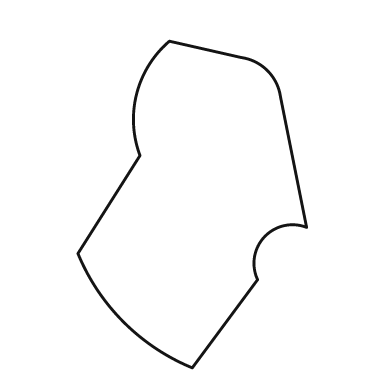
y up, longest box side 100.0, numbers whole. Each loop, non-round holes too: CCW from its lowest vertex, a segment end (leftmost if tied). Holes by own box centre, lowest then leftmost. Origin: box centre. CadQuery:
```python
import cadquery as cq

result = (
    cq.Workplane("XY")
    .moveTo(0.0, -50.0)
    .lineTo(20.0, -23.0)
    .threePointArc((22.0, -10.0), (35.0, -7.0))
    .lineTo(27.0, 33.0)
    .threePointArc((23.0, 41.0), (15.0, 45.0))
    .lineTo(-7.0, 50.0)
    .threePointArc((-17.0, 34.0), (-16.0, 15.0))
    .lineTo(-35.0, -15.0)
    .threePointArc((-21.0, -36.0), (0.0, -50.0))
    .close()
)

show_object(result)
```